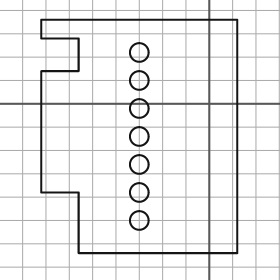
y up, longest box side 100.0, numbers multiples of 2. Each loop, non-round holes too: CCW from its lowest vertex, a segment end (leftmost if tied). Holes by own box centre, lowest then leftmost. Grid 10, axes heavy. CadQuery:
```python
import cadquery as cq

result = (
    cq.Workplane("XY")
    .moveTo(-56.0, -64.0)
    .lineTo(12.0, -64.0)
    .lineTo(12.0, 36.0)
    .lineTo(-72.0, 36.0)
    .lineTo(-72.0, 28.0)
    .lineTo(-56.0, 28.0)
    .lineTo(-56.0, 14.0)
    .lineTo(-72.0, 14.0)
    .lineTo(-72.0, -38.0)
    .lineTo(-56.0, -38.0)
    .close()
    .moveTo(-30.0, -50.0)
    .circle(4.0)
    .moveTo(-30.0, -38.0)
    .circle(4.0)
    .moveTo(-30.0, -26.0)
    .circle(4.0)
    .moveTo(-30.0, -14.0)
    .circle(4.0)
    .moveTo(-30.0, -2.0)
    .circle(4.0)
    .moveTo(-30.0, 10.0)
    .circle(4.0)
    .moveTo(-30.0, 22.0)
    .circle(4.0)
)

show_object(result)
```